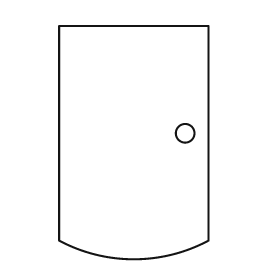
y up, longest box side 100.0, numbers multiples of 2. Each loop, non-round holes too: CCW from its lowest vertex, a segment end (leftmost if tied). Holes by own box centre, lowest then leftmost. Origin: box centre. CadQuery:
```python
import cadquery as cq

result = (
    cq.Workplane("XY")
    .moveTo(-32.0, -42.0)
    .threePointArc((0.0, -50.0), (32.0, -42.0))
    .lineTo(32.0, 50.0)
    .lineTo(-32.0, 50.0)
    .close()
    .moveTo(22.0, 4.0)
    .circle(4.0)
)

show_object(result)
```